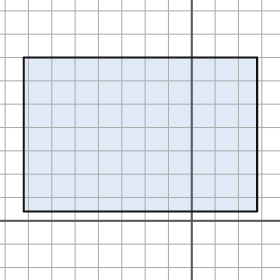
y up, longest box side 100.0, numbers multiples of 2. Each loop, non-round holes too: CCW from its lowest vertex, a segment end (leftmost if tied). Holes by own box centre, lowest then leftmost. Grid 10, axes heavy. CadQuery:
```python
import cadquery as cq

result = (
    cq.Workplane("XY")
    .moveTo(-72.0, 4.0)
    .lineTo(28.0, 4.0)
    .lineTo(28.0, 70.0)
    .lineTo(-72.0, 70.0)
    .close()
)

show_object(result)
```